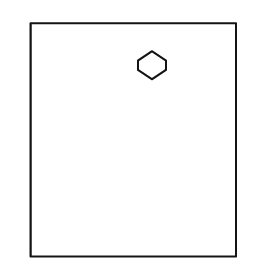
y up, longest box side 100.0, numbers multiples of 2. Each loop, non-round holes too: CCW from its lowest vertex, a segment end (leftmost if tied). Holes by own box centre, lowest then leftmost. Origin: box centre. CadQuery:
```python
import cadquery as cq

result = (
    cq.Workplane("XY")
    .moveTo(-44.0, -50.0)
    .lineTo(44.0, -50.0)
    .lineTo(44.0, 50.0)
    .lineTo(-44.0, 50.0)
    .close()
    .moveTo(8.0, 26.0)
    .lineTo(14.0, 30.0)
    .lineTo(14.0, 34.0)
    .lineTo(8.0, 38.0)
    .lineTo(2.0, 34.0)
    .lineTo(2.0, 30.0)
    .close()
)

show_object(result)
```